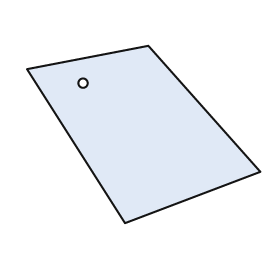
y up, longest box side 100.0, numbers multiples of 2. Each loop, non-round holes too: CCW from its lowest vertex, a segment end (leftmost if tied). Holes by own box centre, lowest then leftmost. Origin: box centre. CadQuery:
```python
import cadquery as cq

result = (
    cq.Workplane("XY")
    .moveTo(-8.0, -38.0)
    .lineTo(50.0, -16.0)
    .lineTo(2.0, 38.0)
    .lineTo(-50.0, 28.0)
    .close()
    .moveTo(-26.0, 22.0)
    .circle(2.0)
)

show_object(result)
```